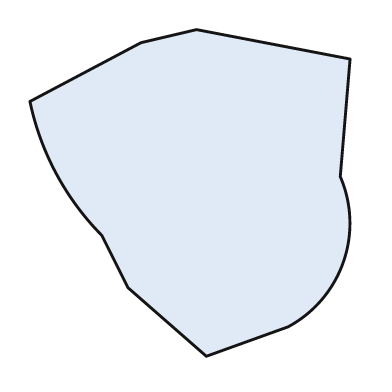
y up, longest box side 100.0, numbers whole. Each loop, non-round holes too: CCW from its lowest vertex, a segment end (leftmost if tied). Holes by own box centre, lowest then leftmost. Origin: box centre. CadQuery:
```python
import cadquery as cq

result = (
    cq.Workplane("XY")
    .moveTo(5.0, -50.0)
    .lineTo(30.0, -41.0)
    .threePointArc((47.0, -21.0), (46.0, 5.0))
    .lineTo(49.0, 41.0)
    .lineTo(2.0, 50.0)
    .lineTo(-15.0, 46.0)
    .lineTo(-49.0, 28.0)
    .threePointArc((-41.0, 6.0), (-27.0, -13.0))
    .lineTo(-19.0, -29.0)
    .close()
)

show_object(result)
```